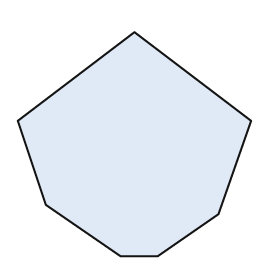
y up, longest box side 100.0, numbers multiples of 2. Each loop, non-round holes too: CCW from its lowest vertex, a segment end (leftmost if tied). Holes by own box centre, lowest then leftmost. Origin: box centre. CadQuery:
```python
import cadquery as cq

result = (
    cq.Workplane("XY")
    .moveTo(-6.0, -48.0)
    .lineTo(10.0, -48.0)
    .lineTo(36.0, -30.0)
    .lineTo(50.0, 10.0)
    .lineTo(0.0, 48.0)
    .lineTo(-50.0, 10.0)
    .lineTo(-38.0, -26.0)
    .close()
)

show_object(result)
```